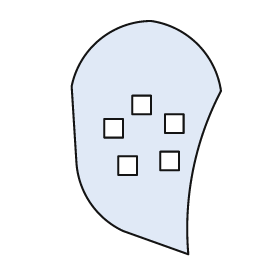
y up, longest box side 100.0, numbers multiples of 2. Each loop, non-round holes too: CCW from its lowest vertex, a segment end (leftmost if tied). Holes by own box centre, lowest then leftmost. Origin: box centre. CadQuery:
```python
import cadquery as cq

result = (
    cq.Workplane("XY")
    .moveTo(18.0, -50.0)
    .threePointArc((20.0, -14.0), (32.0, 20.0))
    .threePointArc((22.0, 40.0), (2.0, 50.0))
    .threePointArc((-20.0, 42.0), (-32.0, 22.0))
    .lineTo(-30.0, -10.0)
    .threePointArc((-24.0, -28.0), (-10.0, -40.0))
    .close()
    .moveTo(-12.0, -16.0)
    .lineTo(-4.0, -16.0)
    .lineTo(-4.0, -8.0)
    .lineTo(-12.0, -8.0)
    .close()
    .moveTo(6.0, -14.0)
    .lineTo(14.0, -14.0)
    .lineTo(14.0, -6.0)
    .lineTo(6.0, -6.0)
    .close()
    .moveTo(-18.0, 0.0)
    .lineTo(-10.0, 0.0)
    .lineTo(-10.0, 8.0)
    .lineTo(-18.0, 8.0)
    .close()
    .moveTo(8.0, 2.0)
    .lineTo(16.0, 2.0)
    .lineTo(16.0, 10.0)
    .lineTo(8.0, 10.0)
    .close()
    .moveTo(-6.0, 10.0)
    .lineTo(2.0, 10.0)
    .lineTo(2.0, 18.0)
    .lineTo(-6.0, 18.0)
    .close()
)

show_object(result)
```